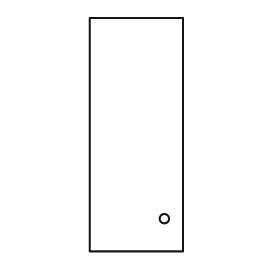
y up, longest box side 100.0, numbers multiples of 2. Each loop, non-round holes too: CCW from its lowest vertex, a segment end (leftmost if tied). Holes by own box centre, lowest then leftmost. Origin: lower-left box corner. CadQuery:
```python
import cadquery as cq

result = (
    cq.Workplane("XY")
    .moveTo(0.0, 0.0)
    .lineTo(40.0, 0.0)
    .lineTo(40.0, 100.0)
    .lineTo(0.0, 100.0)
    .close()
    .moveTo(32.0, 14.0)
    .circle(2.0)
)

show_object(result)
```